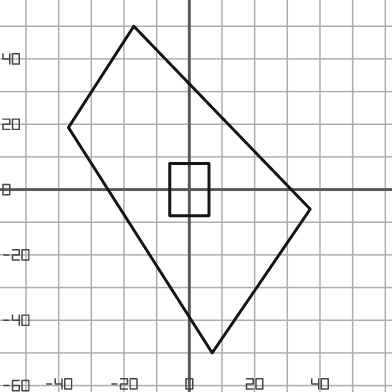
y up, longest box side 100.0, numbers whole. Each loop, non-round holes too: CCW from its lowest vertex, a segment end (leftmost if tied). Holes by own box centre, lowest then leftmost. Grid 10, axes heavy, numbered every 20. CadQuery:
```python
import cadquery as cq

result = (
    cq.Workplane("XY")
    .moveTo(7.0, -50.0)
    .lineTo(37.0, -6.0)
    .lineTo(-17.0, 50.0)
    .lineTo(-37.0, 19.0)
    .close()
    .moveTo(-6.0, -8.0)
    .lineTo(6.0, -8.0)
    .lineTo(6.0, 8.0)
    .lineTo(-6.0, 8.0)
    .close()
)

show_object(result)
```